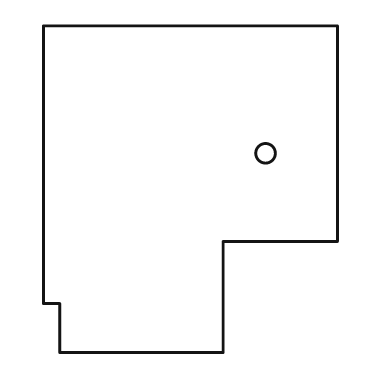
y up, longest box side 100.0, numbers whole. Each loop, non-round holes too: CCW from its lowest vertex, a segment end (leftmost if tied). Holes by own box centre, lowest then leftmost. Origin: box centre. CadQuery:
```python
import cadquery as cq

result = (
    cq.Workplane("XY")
    .moveTo(-40.0, -50.0)
    .lineTo(10.0, -50.0)
    .lineTo(10.0, -16.0)
    .lineTo(45.0, -16.0)
    .lineTo(45.0, 50.0)
    .lineTo(-45.0, 50.0)
    .lineTo(-45.0, -35.0)
    .lineTo(-40.0, -35.0)
    .close()
    .moveTo(23.0, 11.0)
    .circle(3.0)
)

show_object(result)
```